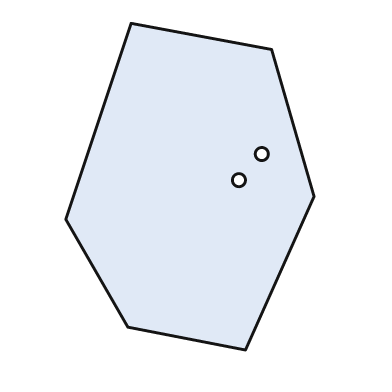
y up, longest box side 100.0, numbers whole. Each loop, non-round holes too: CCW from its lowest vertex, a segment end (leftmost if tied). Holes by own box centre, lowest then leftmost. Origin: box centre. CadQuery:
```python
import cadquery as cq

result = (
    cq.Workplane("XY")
    .moveTo(17.0, -50.0)
    .lineTo(38.0, -3.0)
    .lineTo(25.0, 42.0)
    .lineTo(-18.0, 50.0)
    .lineTo(-38.0, -10.0)
    .lineTo(-19.0, -43.0)
    .close()
    .moveTo(15.0, 2.0)
    .circle(2.0)
    .moveTo(22.0, 10.0)
    .circle(2.0)
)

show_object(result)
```